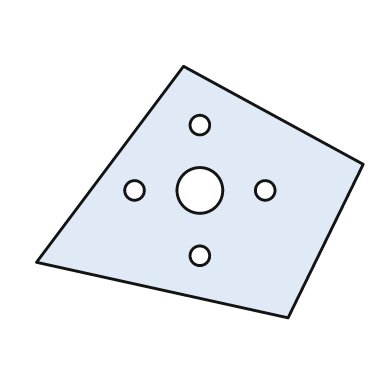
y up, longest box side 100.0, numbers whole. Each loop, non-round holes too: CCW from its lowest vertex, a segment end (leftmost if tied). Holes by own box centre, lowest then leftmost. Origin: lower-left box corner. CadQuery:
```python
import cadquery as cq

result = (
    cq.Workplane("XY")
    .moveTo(77.0, 0.0)
    .lineTo(100.0, 47.0)
    .lineTo(45.0, 77.0)
    .lineTo(0.0, 17.0)
    .close()
    .moveTo(50.0, 19.0)
    .circle(3.0)
    .moveTo(30.0, 39.0)
    .circle(3.0)
    .moveTo(50.0, 39.0)
    .circle(7.0)
    .moveTo(70.0, 39.0)
    .circle(3.0)
    .moveTo(50.0, 59.0)
    .circle(3.0)
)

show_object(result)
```